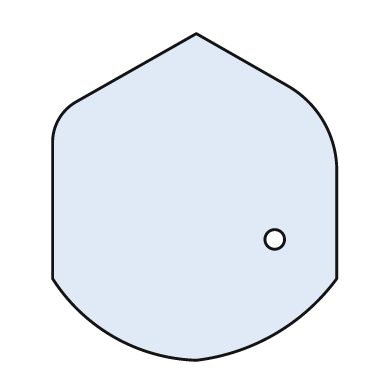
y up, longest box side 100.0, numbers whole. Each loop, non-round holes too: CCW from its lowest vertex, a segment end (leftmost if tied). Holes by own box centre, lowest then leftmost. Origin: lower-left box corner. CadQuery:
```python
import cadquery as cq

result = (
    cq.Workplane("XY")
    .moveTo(44.0, 0.0)
    .threePointArc((68.0, 8.0), (87.0, 25.0))
    .lineTo(87.0, 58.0)
    .threePointArc((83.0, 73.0), (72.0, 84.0))
    .lineTo(44.0, 100.0)
    .lineTo(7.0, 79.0)
    .threePointArc((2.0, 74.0), (0.0, 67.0))
    .lineTo(0.0, 25.0)
    .threePointArc((19.0, 7.0), (44.0, 0.0))
    .close()
    .moveTo(68.0, 37.0)
    .circle(3.0)
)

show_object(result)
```